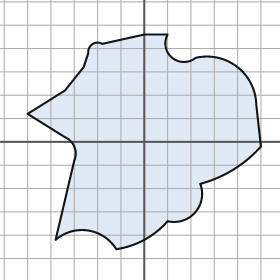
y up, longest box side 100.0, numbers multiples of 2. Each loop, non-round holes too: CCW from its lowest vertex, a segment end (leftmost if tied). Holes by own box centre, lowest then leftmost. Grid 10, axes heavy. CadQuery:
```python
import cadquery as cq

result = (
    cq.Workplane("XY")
    .moveTo(-12.0, -46.0)
    .threePointArc((0.0, -42.0), (10.0, -34.0))
    .threePointArc((22.0, -30.0), (24.0, -18.0))
    .threePointArc((38.0, -12.0), (50.0, -2.0))
    .lineTo(48.0, 16.0)
    .threePointArc((40.0, 32.0), (22.0, 36.0))
    .threePointArc((12.0, 36.0), (10.0, 46.0))
    .lineTo(0.0, 46.0)
    .lineTo(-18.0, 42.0)
    .threePointArc((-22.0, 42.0), (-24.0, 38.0))
    .lineTo(-26.0, 32.0)
    .lineTo(-34.0, 22.0)
    .lineTo(-50.0, 12.0)
    .lineTo(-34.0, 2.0)
    .threePointArc((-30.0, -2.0), (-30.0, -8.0))
    .lineTo(-38.0, -42.0)
    .threePointArc((-24.0, -38.0), (-12.0, -46.0))
    .close()
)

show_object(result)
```